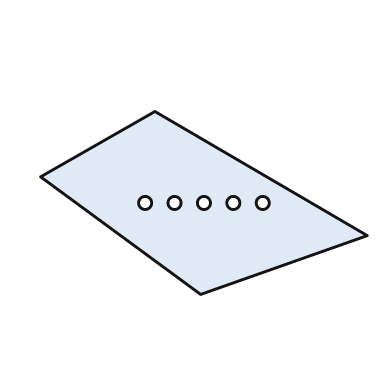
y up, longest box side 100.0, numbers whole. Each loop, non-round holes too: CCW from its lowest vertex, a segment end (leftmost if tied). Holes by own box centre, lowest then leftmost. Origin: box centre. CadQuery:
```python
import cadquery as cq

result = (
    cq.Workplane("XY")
    .moveTo(-1.0, -28.0)
    .lineTo(50.0, -10.0)
    .lineTo(-15.0, 28.0)
    .lineTo(-50.0, 8.0)
    .close()
    .moveTo(-18.0, 0.0)
    .circle(2.0)
    .moveTo(-9.0, 0.0)
    .circle(2.0)
    .moveTo(0.0, 0.0)
    .circle(2.0)
    .moveTo(9.0, 0.0)
    .circle(2.0)
    .moveTo(18.0, 0.0)
    .circle(2.0)
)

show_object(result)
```